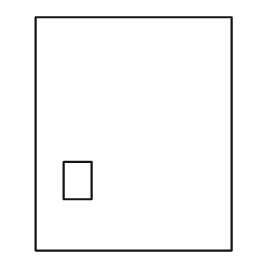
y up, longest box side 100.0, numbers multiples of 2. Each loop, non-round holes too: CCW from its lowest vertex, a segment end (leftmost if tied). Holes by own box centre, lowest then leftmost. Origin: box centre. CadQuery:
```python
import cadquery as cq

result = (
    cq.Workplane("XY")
    .moveTo(-42.0, -50.0)
    .lineTo(42.0, -50.0)
    .lineTo(42.0, 50.0)
    .lineTo(-42.0, 50.0)
    .close()
    .moveTo(-30.0, -28.0)
    .lineTo(-18.0, -28.0)
    .lineTo(-18.0, -12.0)
    .lineTo(-30.0, -12.0)
    .close()
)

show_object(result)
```